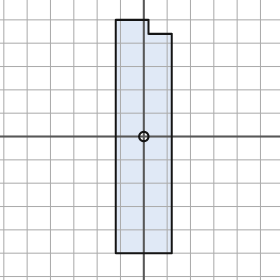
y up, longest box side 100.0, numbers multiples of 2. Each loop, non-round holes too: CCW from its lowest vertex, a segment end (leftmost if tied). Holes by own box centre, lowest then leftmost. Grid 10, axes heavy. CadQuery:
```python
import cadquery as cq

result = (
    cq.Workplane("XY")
    .moveTo(-12.0, -50.0)
    .lineTo(12.0, -50.0)
    .lineTo(12.0, 44.0)
    .lineTo(2.0, 44.0)
    .lineTo(2.0, 50.0)
    .lineTo(-12.0, 50.0)
    .close()
    .moveTo(0.0, 0.0)
    .circle(2.0)
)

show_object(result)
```